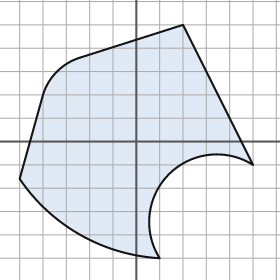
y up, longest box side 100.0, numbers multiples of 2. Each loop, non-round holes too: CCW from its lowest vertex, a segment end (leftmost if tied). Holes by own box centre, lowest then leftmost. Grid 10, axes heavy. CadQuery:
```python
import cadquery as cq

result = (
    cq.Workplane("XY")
    .moveTo(10.0, -50.0)
    .threePointArc((14.0, -14.0), (50.0, -10.0))
    .lineTo(20.0, 50.0)
    .lineTo(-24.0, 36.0)
    .threePointArc((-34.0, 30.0), (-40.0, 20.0))
    .lineTo(-50.0, -16.0)
    .threePointArc((-24.0, -40.0), (10.0, -50.0))
    .close()
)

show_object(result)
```